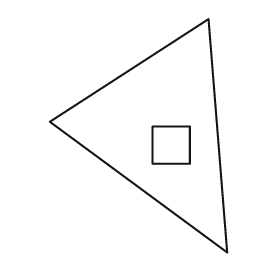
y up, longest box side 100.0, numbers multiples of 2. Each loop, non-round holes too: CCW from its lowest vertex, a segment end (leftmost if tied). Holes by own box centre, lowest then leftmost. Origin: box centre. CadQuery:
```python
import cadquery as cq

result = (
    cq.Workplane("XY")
    .moveTo(38.0, -50.0)
    .lineTo(30.0, 50.0)
    .lineTo(-38.0, 6.0)
    .close()
    .moveTo(6.0, -12.0)
    .lineTo(22.0, -12.0)
    .lineTo(22.0, 4.0)
    .lineTo(6.0, 4.0)
    .close()
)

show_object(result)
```